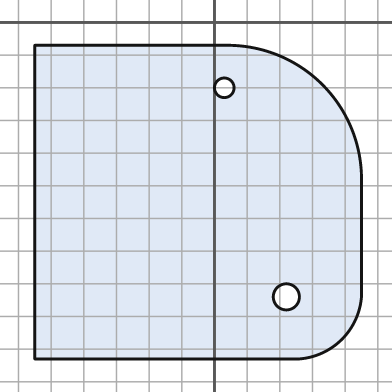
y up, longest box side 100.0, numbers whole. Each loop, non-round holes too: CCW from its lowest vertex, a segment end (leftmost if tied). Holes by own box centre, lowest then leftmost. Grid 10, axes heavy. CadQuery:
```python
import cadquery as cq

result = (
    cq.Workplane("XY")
    .moveTo(-55.0, -103.0)
    .lineTo(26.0, -103.0)
    .threePointArc((39.0, -97.0), (45.0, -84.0))
    .lineTo(45.0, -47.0)
    .threePointArc((33.0, -19.0), (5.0, -7.0))
    .lineTo(-55.0, -7.0)
    .close()
    .moveTo(22.0, -84.0)
    .circle(4.0)
    .moveTo(3.0, -20.0)
    .circle(3.0)
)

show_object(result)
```